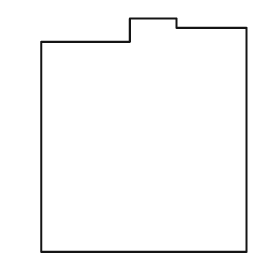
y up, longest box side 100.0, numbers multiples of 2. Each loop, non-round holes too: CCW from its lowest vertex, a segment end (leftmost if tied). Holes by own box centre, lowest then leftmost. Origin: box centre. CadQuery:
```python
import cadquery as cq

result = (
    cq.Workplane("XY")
    .moveTo(-44.0, -50.0)
    .lineTo(44.0, -50.0)
    .lineTo(44.0, 46.0)
    .lineTo(14.0, 46.0)
    .lineTo(14.0, 50.0)
    .lineTo(-6.0, 50.0)
    .lineTo(-6.0, 40.0)
    .lineTo(-44.0, 40.0)
    .close()
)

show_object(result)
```